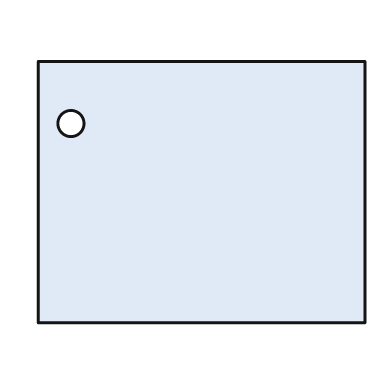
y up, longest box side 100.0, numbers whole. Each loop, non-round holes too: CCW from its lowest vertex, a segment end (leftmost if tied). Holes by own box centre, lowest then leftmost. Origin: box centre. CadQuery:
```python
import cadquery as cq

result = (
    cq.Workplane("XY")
    .moveTo(-50.0, -40.0)
    .lineTo(50.0, -40.0)
    .lineTo(50.0, 40.0)
    .lineTo(-50.0, 40.0)
    .close()
    .moveTo(-40.0, 21.0)
    .circle(4.0)
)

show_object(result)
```